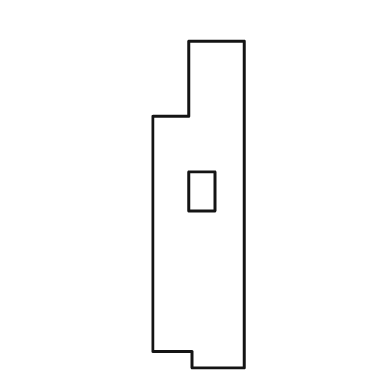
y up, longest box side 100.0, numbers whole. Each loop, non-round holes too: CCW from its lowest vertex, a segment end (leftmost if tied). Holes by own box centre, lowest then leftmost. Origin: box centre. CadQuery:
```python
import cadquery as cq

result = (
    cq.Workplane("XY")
    .moveTo(-2.0, -50.0)
    .lineTo(14.0, -50.0)
    .lineTo(14.0, 50.0)
    .lineTo(-3.0, 50.0)
    .lineTo(-3.0, 27.0)
    .lineTo(-14.0, 27.0)
    .lineTo(-14.0, -45.0)
    .lineTo(-2.0, -45.0)
    .close()
    .moveTo(-3.0, -2.0)
    .lineTo(5.0, -2.0)
    .lineTo(5.0, 10.0)
    .lineTo(-3.0, 10.0)
    .close()
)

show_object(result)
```